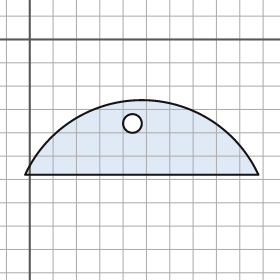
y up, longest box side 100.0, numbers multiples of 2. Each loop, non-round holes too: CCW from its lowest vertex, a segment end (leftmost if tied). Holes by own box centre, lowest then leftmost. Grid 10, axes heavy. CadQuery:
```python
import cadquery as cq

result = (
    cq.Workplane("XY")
    .moveTo(-2.0, -58.0)
    .lineTo(98.0, -58.0)
    .threePointArc((48.0, -26.0), (-2.0, -58.0))
    .close()
    .moveTo(44.0, -36.0)
    .circle(4.0)
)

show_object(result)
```